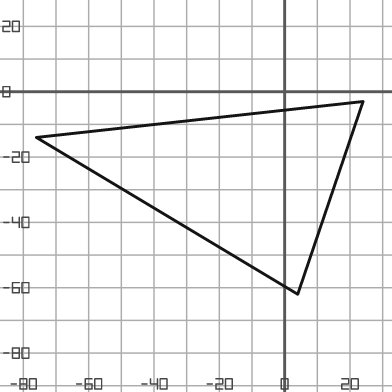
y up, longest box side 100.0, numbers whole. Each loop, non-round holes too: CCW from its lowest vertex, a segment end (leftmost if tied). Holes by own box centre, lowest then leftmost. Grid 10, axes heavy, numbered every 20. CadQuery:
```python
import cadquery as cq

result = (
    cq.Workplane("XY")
    .moveTo(4.0, -62.0)
    .lineTo(24.0, -3.0)
    .lineTo(-76.0, -14.0)
    .close()
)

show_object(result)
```